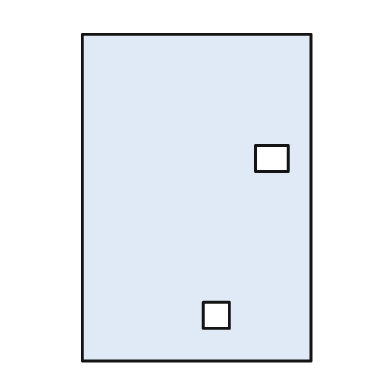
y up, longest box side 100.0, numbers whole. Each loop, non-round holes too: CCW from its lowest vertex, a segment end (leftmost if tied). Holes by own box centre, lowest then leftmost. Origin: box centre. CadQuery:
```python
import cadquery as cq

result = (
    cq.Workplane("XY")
    .moveTo(-35.0, -50.0)
    .lineTo(35.0, -50.0)
    .lineTo(35.0, 50.0)
    .lineTo(-35.0, 50.0)
    .close()
    .moveTo(2.0, -40.0)
    .lineTo(10.0, -40.0)
    .lineTo(10.0, -32.0)
    .lineTo(2.0, -32.0)
    .close()
    .moveTo(18.0, 8.0)
    .lineTo(28.0, 8.0)
    .lineTo(28.0, 16.0)
    .lineTo(18.0, 16.0)
    .close()
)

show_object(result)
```